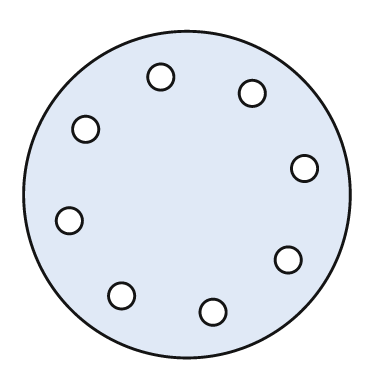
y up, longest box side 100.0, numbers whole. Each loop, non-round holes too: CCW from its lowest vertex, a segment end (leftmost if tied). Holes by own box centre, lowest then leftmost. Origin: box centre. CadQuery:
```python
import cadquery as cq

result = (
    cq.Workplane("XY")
    .moveTo(0.0, 0.0)
    .circle(50.0)
    .moveTo(8.0, -36.0)
    .circle(4.0)
    .moveTo(-20.0, -31.0)
    .circle(4.0)
    .moveTo(31.0, -20.0)
    .circle(4.0)
    .moveTo(-36.0, -8.0)
    .circle(4.0)
    .moveTo(36.0, 8.0)
    .circle(4.0)
    .moveTo(-31.0, 20.0)
    .circle(4.0)
    .moveTo(20.0, 31.0)
    .circle(4.0)
    .moveTo(-8.0, 36.0)
    .circle(4.0)
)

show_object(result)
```